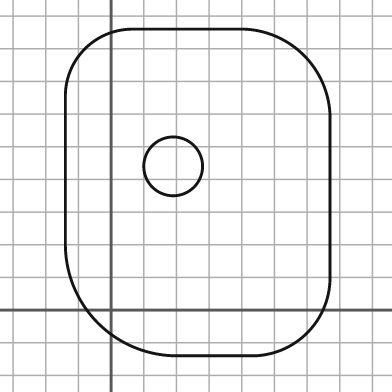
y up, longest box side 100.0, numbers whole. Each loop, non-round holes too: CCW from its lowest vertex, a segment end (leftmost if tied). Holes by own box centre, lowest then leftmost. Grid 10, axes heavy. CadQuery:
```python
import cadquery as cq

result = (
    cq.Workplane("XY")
    .moveTo(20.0, -14.0)
    .lineTo(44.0, -14.0)
    .threePointArc((60.0, -7.0), (67.0, 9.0))
    .lineTo(67.0, 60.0)
    .threePointArc((59.0, 78.0), (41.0, 86.0))
    .lineTo(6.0, 86.0)
    .threePointArc((-8.0, 80.0), (-14.0, 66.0))
    .lineTo(-14.0, 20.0)
    .threePointArc((-4.0, -4.0), (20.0, -14.0))
    .close()
    .moveTo(19.0, 44.0)
    .circle(9.0)
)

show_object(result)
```